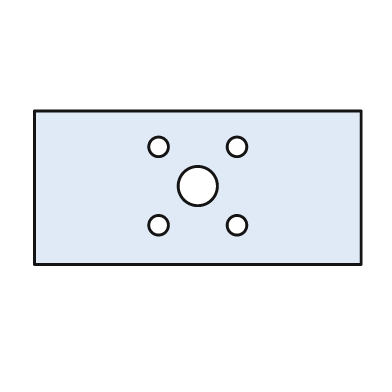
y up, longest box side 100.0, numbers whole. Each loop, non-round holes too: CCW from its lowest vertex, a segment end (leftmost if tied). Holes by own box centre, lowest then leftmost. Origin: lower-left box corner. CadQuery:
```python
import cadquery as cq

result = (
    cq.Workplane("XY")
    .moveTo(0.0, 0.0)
    .lineTo(100.0, 0.0)
    .lineTo(100.0, 47.0)
    .lineTo(0.0, 47.0)
    .close()
    .moveTo(38.0, 12.0)
    .circle(3.0)
    .moveTo(62.0, 12.0)
    .circle(3.0)
    .moveTo(50.0, 24.0)
    .circle(6.0)
    .moveTo(38.0, 36.0)
    .circle(3.0)
    .moveTo(62.0, 36.0)
    .circle(3.0)
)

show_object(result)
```